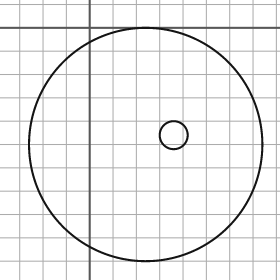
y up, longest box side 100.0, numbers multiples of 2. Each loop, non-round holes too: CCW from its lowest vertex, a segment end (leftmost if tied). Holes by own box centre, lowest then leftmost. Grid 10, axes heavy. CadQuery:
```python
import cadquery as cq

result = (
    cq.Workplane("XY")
    .moveTo(24.0, -50.0)
    .circle(50.0)
    .moveTo(36.0, -46.0)
    .circle(6.0)
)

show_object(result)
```